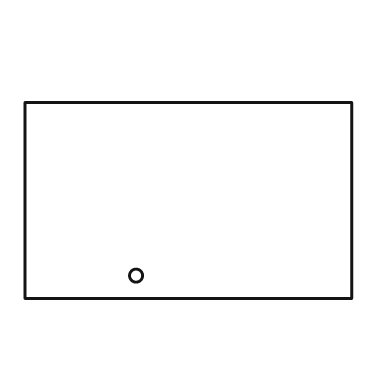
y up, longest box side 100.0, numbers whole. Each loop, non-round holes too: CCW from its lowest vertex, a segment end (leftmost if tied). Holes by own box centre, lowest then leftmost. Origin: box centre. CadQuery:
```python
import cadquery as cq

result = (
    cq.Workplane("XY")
    .moveTo(-50.0, -30.0)
    .lineTo(50.0, -30.0)
    .lineTo(50.0, 30.0)
    .lineTo(-50.0, 30.0)
    .close()
    .moveTo(-16.0, -23.0)
    .circle(2.0)
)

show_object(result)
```